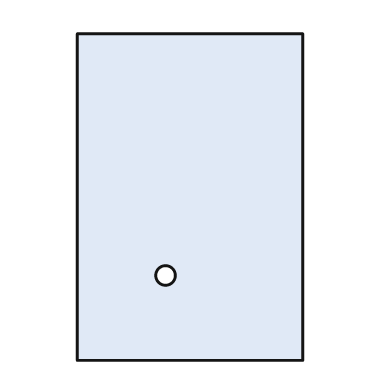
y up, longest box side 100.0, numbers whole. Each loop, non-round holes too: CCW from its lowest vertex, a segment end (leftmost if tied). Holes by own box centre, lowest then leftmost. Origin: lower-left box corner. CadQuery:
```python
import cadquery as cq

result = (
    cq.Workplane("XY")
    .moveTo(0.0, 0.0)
    .lineTo(69.0, 0.0)
    .lineTo(69.0, 100.0)
    .lineTo(0.0, 100.0)
    .close()
    .moveTo(27.0, 26.0)
    .circle(3.0)
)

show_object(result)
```